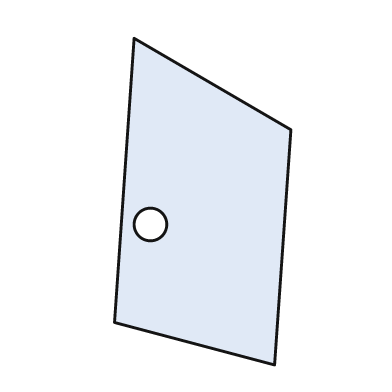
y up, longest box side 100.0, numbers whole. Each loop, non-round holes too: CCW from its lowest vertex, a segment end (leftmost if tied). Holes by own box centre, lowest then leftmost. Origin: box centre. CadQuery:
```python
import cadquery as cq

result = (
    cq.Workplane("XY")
    .moveTo(22.0, -50.0)
    .lineTo(27.0, 22.0)
    .lineTo(-21.0, 50.0)
    .lineTo(-27.0, -37.0)
    .close()
    .moveTo(-16.0, -7.0)
    .circle(5.0)
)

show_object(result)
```